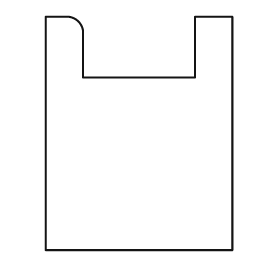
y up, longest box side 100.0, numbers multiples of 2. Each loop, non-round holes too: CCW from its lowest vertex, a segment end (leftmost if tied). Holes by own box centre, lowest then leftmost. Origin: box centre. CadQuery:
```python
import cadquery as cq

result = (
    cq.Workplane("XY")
    .moveTo(-40.0, -50.0)
    .lineTo(40.0, -50.0)
    .lineTo(40.0, 50.0)
    .lineTo(24.0, 50.0)
    .lineTo(24.0, 24.0)
    .lineTo(-24.0, 24.0)
    .lineTo(-24.0, 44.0)
    .threePointArc((-26.0, 48.0), (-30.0, 50.0))
    .lineTo(-40.0, 50.0)
    .close()
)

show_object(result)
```